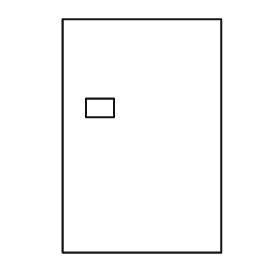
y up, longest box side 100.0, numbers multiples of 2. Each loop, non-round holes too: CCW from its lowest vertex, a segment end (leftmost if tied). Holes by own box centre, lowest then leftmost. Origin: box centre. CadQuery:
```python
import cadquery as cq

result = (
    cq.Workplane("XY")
    .moveTo(-34.0, -50.0)
    .lineTo(34.0, -50.0)
    .lineTo(34.0, 50.0)
    .lineTo(-34.0, 50.0)
    .close()
    .moveTo(-24.0, 8.0)
    .lineTo(-12.0, 8.0)
    .lineTo(-12.0, 16.0)
    .lineTo(-24.0, 16.0)
    .close()
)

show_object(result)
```